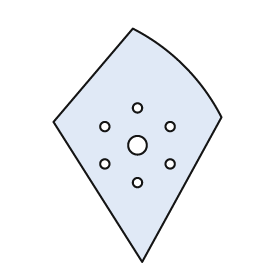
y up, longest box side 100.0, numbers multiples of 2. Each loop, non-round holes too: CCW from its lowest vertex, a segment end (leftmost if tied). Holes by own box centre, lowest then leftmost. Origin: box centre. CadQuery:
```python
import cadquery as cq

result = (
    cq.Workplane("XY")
    .moveTo(2.0, -50.0)
    .lineTo(36.0, 12.0)
    .threePointArc((20.0, 34.0), (-2.0, 50.0))
    .lineTo(-36.0, 10.0)
    .close()
    .moveTo(0.0, -16.0)
    .circle(2.0)
    .moveTo(-14.0, -8.0)
    .circle(2.0)
    .moveTo(14.0, -8.0)
    .circle(2.0)
    .moveTo(0.0, 0.0)
    .circle(4.0)
    .moveTo(-14.0, 8.0)
    .circle(2.0)
    .moveTo(14.0, 8.0)
    .circle(2.0)
    .moveTo(0.0, 16.0)
    .circle(2.0)
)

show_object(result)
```